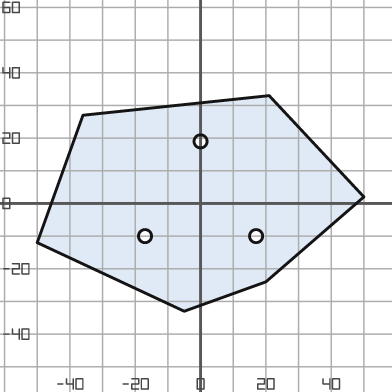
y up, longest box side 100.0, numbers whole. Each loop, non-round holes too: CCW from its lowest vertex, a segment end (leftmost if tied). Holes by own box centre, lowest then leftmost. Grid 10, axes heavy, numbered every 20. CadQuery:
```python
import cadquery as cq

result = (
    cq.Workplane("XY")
    .moveTo(-5.0, -33.0)
    .lineTo(20.0, -24.0)
    .lineTo(50.0, 2.0)
    .lineTo(21.0, 33.0)
    .lineTo(-36.0, 27.0)
    .lineTo(-50.0, -12.0)
    .close()
    .moveTo(-17.0, -10.0)
    .circle(2.0)
    .moveTo(17.0, -10.0)
    .circle(2.0)
    .moveTo(0.0, 19.0)
    .circle(2.0)
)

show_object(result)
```